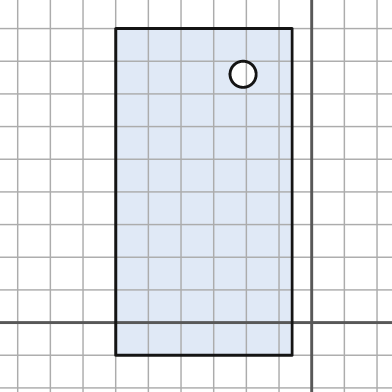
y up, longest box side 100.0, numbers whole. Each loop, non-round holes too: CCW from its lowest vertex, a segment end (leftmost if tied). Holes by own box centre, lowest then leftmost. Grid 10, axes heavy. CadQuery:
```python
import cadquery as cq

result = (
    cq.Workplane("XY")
    .moveTo(-60.0, -10.0)
    .lineTo(-6.0, -10.0)
    .lineTo(-6.0, 90.0)
    .lineTo(-60.0, 90.0)
    .close()
    .moveTo(-21.0, 76.0)
    .circle(4.0)
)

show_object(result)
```